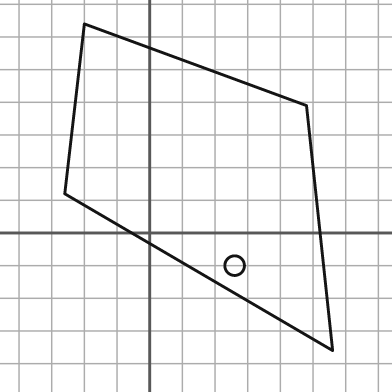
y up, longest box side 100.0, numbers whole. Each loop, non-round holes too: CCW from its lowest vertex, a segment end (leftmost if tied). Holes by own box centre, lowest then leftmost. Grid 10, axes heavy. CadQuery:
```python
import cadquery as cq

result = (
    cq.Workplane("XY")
    .moveTo(56.0, -36.0)
    .lineTo(48.0, 39.0)
    .lineTo(-20.0, 64.0)
    .lineTo(-26.0, 12.0)
    .close()
    .moveTo(26.0, -10.0)
    .circle(3.0)
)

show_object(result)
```